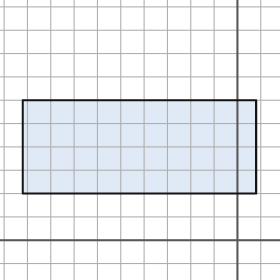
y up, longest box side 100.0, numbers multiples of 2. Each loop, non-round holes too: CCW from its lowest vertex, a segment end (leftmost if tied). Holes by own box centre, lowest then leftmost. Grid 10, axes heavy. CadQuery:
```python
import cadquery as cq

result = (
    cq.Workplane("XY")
    .moveTo(-92.0, 20.0)
    .lineTo(8.0, 20.0)
    .lineTo(8.0, 60.0)
    .lineTo(-92.0, 60.0)
    .close()
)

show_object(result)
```